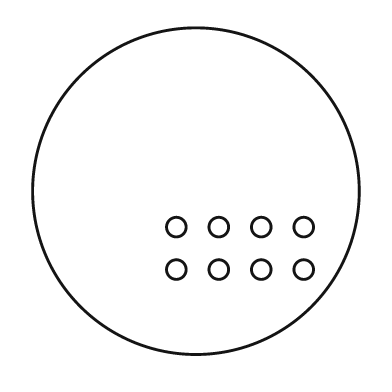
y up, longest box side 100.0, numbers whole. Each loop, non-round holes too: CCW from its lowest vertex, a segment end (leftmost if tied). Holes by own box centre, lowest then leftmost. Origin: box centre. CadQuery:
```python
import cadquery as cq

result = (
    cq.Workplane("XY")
    .moveTo(0.0, 0.0)
    .circle(50.0)
    .moveTo(-6.0, -24.0)
    .circle(3.0)
    .moveTo(7.0, -24.0)
    .circle(3.0)
    .moveTo(20.0, -24.0)
    .circle(3.0)
    .moveTo(33.0, -24.0)
    .circle(3.0)
    .moveTo(-6.0, -11.0)
    .circle(3.0)
    .moveTo(7.0, -11.0)
    .circle(3.0)
    .moveTo(20.0, -11.0)
    .circle(3.0)
    .moveTo(33.0, -11.0)
    .circle(3.0)
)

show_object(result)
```